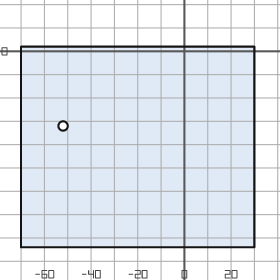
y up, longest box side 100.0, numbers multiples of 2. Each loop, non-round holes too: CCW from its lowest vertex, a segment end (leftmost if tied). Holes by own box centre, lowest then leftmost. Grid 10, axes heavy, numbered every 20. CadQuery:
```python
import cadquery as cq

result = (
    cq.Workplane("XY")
    .moveTo(-70.0, -84.0)
    .lineTo(30.0, -84.0)
    .lineTo(30.0, 2.0)
    .lineTo(-70.0, 2.0)
    .close()
    .moveTo(-52.0, -32.0)
    .circle(2.0)
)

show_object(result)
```